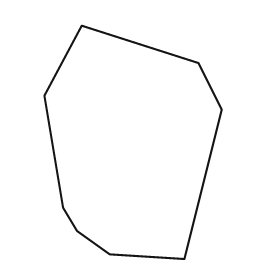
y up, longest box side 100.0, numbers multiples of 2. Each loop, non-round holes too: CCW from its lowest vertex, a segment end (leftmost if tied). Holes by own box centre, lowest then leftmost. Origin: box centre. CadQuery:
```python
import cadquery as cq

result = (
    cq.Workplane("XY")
    .moveTo(22.0, -50.0)
    .lineTo(38.0, 14.0)
    .lineTo(28.0, 34.0)
    .lineTo(-22.0, 50.0)
    .lineTo(-38.0, 20.0)
    .lineTo(-30.0, -28.0)
    .lineTo(-24.0, -38.0)
    .lineTo(-10.0, -48.0)
    .close()
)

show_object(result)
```